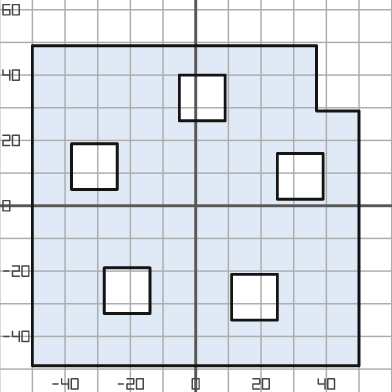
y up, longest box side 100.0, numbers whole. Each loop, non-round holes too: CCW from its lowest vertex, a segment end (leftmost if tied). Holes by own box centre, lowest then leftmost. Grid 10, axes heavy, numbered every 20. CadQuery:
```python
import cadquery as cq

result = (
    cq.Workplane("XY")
    .moveTo(-50.0, -49.0)
    .lineTo(50.0, -49.0)
    .lineTo(50.0, 29.0)
    .lineTo(37.0, 29.0)
    .lineTo(37.0, 49.0)
    .lineTo(-50.0, 49.0)
    .close()
    .moveTo(11.0, -35.0)
    .lineTo(25.0, -35.0)
    .lineTo(25.0, -21.0)
    .lineTo(11.0, -21.0)
    .close()
    .moveTo(-28.0, -33.0)
    .lineTo(-14.0, -33.0)
    .lineTo(-14.0, -19.0)
    .lineTo(-28.0, -19.0)
    .close()
    .moveTo(25.0, 2.0)
    .lineTo(39.0, 2.0)
    .lineTo(39.0, 16.0)
    .lineTo(25.0, 16.0)
    .close()
    .moveTo(-38.0, 5.0)
    .lineTo(-24.0, 5.0)
    .lineTo(-24.0, 19.0)
    .lineTo(-38.0, 19.0)
    .close()
    .moveTo(-5.0, 26.0)
    .lineTo(9.0, 26.0)
    .lineTo(9.0, 40.0)
    .lineTo(-5.0, 40.0)
    .close()
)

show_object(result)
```